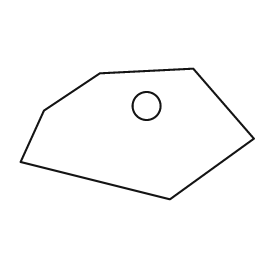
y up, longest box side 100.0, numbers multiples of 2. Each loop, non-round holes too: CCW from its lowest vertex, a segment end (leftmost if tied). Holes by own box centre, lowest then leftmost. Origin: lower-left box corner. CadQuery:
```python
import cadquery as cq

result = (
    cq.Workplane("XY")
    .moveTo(64.0, 0.0)
    .lineTo(100.0, 26.0)
    .lineTo(74.0, 56.0)
    .lineTo(34.0, 54.0)
    .lineTo(10.0, 38.0)
    .lineTo(0.0, 16.0)
    .close()
    .moveTo(54.0, 40.0)
    .circle(6.0)
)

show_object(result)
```